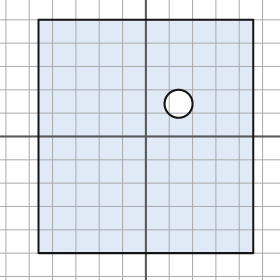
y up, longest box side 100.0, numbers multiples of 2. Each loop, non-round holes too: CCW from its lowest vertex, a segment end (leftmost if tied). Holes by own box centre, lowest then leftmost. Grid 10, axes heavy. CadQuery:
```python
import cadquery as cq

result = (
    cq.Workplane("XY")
    .moveTo(-46.0, -50.0)
    .lineTo(46.0, -50.0)
    .lineTo(46.0, 50.0)
    .lineTo(-46.0, 50.0)
    .close()
    .moveTo(14.0, 14.0)
    .circle(6.0)
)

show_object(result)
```